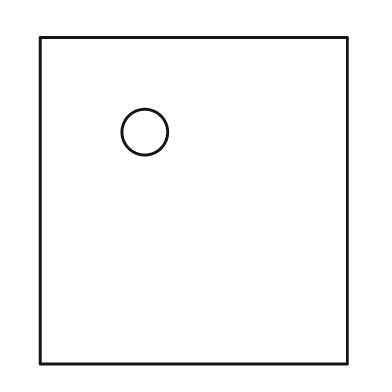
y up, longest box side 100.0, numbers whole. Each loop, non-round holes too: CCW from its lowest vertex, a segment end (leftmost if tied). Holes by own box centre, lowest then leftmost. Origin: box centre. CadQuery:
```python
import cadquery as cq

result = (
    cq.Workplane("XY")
    .moveTo(-47.0, -50.0)
    .lineTo(47.0, -50.0)
    .lineTo(47.0, 50.0)
    .lineTo(-47.0, 50.0)
    .close()
    .moveTo(-15.0, 21.0)
    .circle(7.0)
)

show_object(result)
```